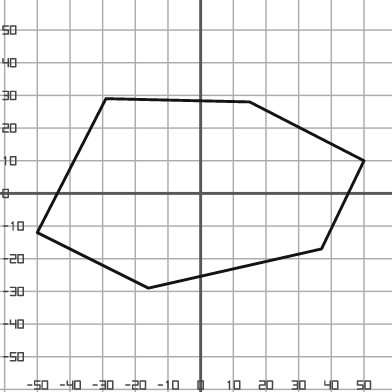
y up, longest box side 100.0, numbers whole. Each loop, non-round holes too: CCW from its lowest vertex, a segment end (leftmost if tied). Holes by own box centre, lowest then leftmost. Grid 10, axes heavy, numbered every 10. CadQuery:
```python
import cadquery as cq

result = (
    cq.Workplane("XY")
    .moveTo(-16.0, -29.0)
    .lineTo(37.0, -17.0)
    .lineTo(50.0, 10.0)
    .lineTo(15.0, 28.0)
    .lineTo(-29.0, 29.0)
    .lineTo(-50.0, -12.0)
    .close()
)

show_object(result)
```